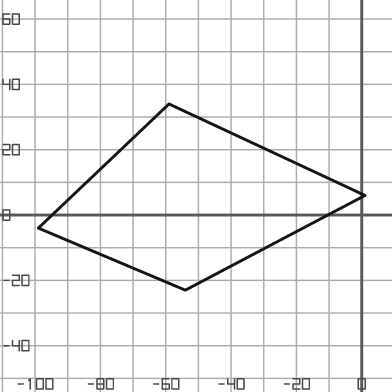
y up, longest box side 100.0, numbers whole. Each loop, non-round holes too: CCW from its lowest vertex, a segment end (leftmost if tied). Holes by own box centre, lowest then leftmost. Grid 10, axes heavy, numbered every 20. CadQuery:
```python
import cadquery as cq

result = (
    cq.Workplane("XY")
    .moveTo(-54.0, -23.0)
    .lineTo(1.0, 6.0)
    .lineTo(-59.0, 34.0)
    .lineTo(-99.0, -4.0)
    .close()
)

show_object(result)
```